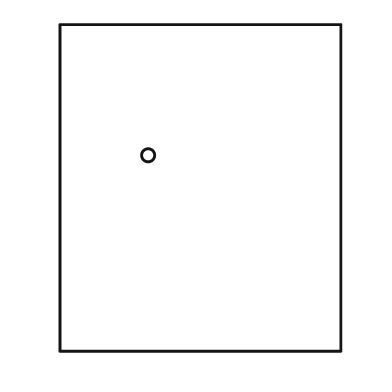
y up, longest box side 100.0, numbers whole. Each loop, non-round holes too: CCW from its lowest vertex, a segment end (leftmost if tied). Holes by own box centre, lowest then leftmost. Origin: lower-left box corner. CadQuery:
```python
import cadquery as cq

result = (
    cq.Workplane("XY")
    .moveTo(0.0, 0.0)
    .lineTo(86.0, 0.0)
    .lineTo(86.0, 100.0)
    .lineTo(0.0, 100.0)
    .close()
    .moveTo(27.0, 60.0)
    .circle(2.0)
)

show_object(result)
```